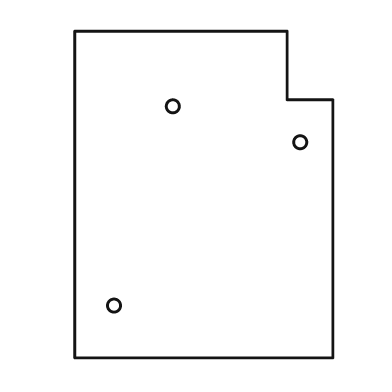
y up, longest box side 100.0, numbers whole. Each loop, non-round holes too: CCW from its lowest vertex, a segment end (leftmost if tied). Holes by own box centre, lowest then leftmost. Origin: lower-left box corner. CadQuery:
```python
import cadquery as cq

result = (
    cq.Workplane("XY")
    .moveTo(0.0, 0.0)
    .lineTo(79.0, 0.0)
    .lineTo(79.0, 79.0)
    .lineTo(65.0, 79.0)
    .lineTo(65.0, 100.0)
    .lineTo(0.0, 100.0)
    .close()
    .moveTo(12.0, 16.0)
    .circle(2.0)
    .moveTo(69.0, 66.0)
    .circle(2.0)
    .moveTo(30.0, 77.0)
    .circle(2.0)
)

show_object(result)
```